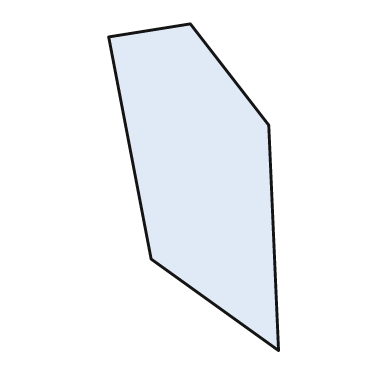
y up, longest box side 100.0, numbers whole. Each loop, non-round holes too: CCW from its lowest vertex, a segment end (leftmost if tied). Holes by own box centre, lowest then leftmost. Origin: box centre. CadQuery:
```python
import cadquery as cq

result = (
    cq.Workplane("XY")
    .moveTo(26.0, -50.0)
    .lineTo(23.0, 19.0)
    .lineTo(-1.0, 50.0)
    .lineTo(-26.0, 46.0)
    .lineTo(-13.0, -22.0)
    .close()
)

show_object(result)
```